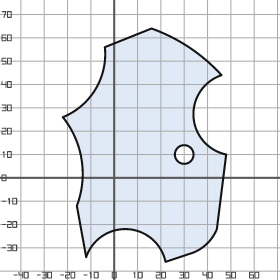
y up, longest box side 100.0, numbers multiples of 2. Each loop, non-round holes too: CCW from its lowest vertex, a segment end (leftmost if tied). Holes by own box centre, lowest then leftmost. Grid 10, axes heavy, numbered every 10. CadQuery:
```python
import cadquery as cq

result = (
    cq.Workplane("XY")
    .moveTo(22.0, -36.0)
    .lineTo(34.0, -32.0)
    .threePointArc((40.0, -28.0), (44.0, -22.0))
    .lineTo(48.0, 10.0)
    .threePointArc((34.0, 26.0), (46.0, 44.0))
    .threePointArc((32.0, 56.0), (16.0, 64.0))
    .lineTo(-4.0, 56.0)
    .threePointArc((-8.0, 38.0), (-22.0, 26.0))
    .threePointArc((-14.0, 8.0), (-16.0, -12.0))
    .lineTo(-12.0, -34.0)
    .threePointArc((6.0, -22.0), (22.0, -36.0))
    .close()
    .moveTo(30.0, 10.0)
    .circle(4.0)
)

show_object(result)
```